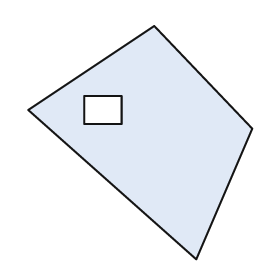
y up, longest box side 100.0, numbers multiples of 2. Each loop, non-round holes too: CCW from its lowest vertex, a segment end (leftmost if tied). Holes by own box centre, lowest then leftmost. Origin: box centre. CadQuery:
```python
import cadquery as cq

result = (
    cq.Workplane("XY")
    .moveTo(24.0, -50.0)
    .lineTo(48.0, 6.0)
    .lineTo(6.0, 50.0)
    .lineTo(-48.0, 14.0)
    .close()
    .moveTo(-24.0, 8.0)
    .lineTo(-8.0, 8.0)
    .lineTo(-8.0, 20.0)
    .lineTo(-24.0, 20.0)
    .close()
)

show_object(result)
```